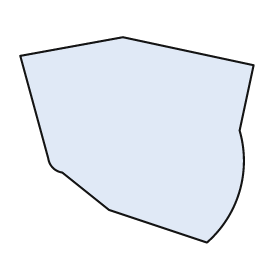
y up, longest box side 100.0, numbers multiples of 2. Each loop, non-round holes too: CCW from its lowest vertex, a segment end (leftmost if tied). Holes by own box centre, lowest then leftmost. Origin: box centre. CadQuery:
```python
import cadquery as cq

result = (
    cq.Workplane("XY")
    .moveTo(30.0, -44.0)
    .threePointArc((44.0, -22.0), (44.0, 4.0))
    .lineTo(50.0, 32.0)
    .lineTo(-6.0, 44.0)
    .lineTo(-50.0, 36.0)
    .lineTo(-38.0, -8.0)
    .threePointArc((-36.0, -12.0), (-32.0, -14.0))
    .lineTo(-12.0, -30.0)
    .close()
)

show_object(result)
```